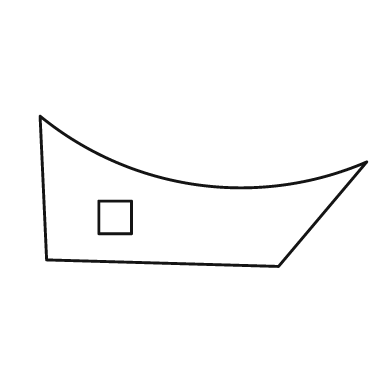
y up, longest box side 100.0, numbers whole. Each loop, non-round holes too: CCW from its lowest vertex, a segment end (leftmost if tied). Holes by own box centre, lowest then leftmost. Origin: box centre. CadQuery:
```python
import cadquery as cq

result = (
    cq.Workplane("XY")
    .moveTo(23.0, -23.0)
    .lineTo(50.0, 9.0)
    .threePointArc((-2.0, 2.0), (-50.0, 23.0))
    .lineTo(-48.0, -21.0)
    .close()
    .moveTo(-32.0, -13.0)
    .lineTo(-22.0, -13.0)
    .lineTo(-22.0, -3.0)
    .lineTo(-32.0, -3.0)
    .close()
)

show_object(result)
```